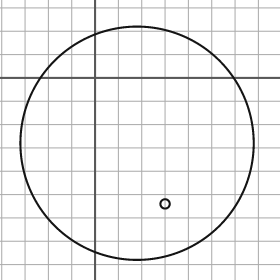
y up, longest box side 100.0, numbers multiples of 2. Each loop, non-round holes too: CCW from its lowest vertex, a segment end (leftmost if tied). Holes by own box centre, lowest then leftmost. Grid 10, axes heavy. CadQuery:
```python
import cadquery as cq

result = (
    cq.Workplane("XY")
    .moveTo(18.0, -28.0)
    .circle(50.0)
    .moveTo(30.0, -54.0)
    .circle(2.0)
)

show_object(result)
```